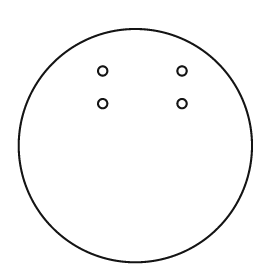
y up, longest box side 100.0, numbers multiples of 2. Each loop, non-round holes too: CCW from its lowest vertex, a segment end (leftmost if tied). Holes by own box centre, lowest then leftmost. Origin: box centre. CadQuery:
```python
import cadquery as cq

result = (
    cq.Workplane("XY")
    .moveTo(0.0, 0.0)
    .circle(50.0)
    .moveTo(-14.0, 18.0)
    .circle(2.0)
    .moveTo(20.0, 18.0)
    .circle(2.0)
    .moveTo(-14.0, 32.0)
    .circle(2.0)
    .moveTo(20.0, 32.0)
    .circle(2.0)
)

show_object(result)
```